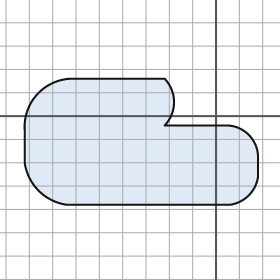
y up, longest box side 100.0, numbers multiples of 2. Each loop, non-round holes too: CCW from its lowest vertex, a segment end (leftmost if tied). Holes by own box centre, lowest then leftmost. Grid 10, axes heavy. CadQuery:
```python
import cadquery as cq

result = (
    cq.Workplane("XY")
    .moveTo(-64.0, -38.0)
    .lineTo(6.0, -38.0)
    .threePointArc((14.0, -34.0), (18.0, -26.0))
    .lineTo(18.0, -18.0)
    .threePointArc((14.0, -8.0), (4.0, -4.0))
    .lineTo(-22.0, -4.0)
    .threePointArc((-18.0, 6.0), (-22.0, 16.0))
    .lineTo(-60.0, 16.0)
    .threePointArc((-76.0, 10.0), (-82.0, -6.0))
    .lineTo(-82.0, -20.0)
    .threePointArc((-76.0, -32.0), (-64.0, -38.0))
    .close()
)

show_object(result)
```